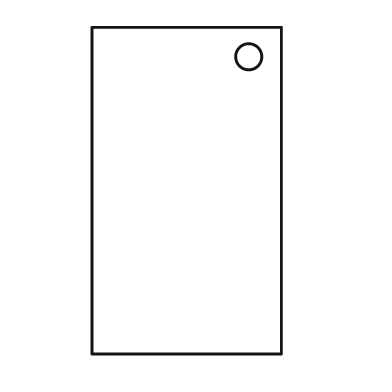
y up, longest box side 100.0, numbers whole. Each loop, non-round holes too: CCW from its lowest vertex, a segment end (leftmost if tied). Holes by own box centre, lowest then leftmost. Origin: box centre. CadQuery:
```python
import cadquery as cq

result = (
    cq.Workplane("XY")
    .moveTo(-29.0, -50.0)
    .lineTo(29.0, -50.0)
    .lineTo(29.0, 50.0)
    .lineTo(-29.0, 50.0)
    .close()
    .moveTo(19.0, 41.0)
    .circle(4.0)
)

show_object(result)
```